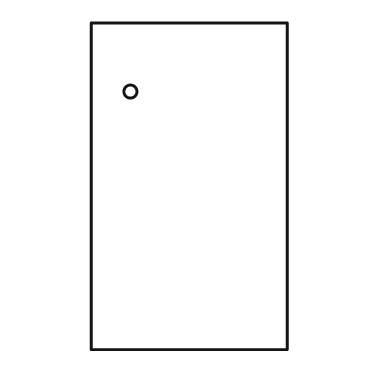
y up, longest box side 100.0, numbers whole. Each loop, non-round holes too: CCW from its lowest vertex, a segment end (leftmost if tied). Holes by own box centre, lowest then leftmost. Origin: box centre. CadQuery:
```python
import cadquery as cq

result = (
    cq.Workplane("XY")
    .moveTo(-30.0, -50.0)
    .lineTo(30.0, -50.0)
    .lineTo(30.0, 50.0)
    .lineTo(-30.0, 50.0)
    .close()
    .moveTo(-18.0, 29.0)
    .circle(2.0)
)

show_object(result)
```